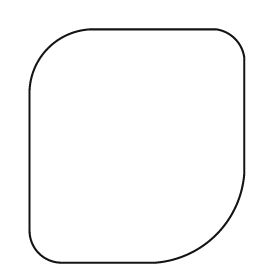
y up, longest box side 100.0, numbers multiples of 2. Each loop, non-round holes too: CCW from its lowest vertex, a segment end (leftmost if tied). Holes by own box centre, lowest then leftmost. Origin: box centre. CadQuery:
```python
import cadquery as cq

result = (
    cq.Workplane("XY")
    .moveTo(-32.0, -50.0)
    .lineTo(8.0, -50.0)
    .threePointArc((34.0, -38.0), (46.0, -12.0))
    .lineTo(46.0, 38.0)
    .threePointArc((42.0, 46.0), (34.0, 50.0))
    .lineTo(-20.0, 50.0)
    .threePointArc((-38.0, 42.0), (-46.0, 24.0))
    .lineTo(-46.0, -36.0)
    .threePointArc((-42.0, -46.0), (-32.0, -50.0))
    .close()
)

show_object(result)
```